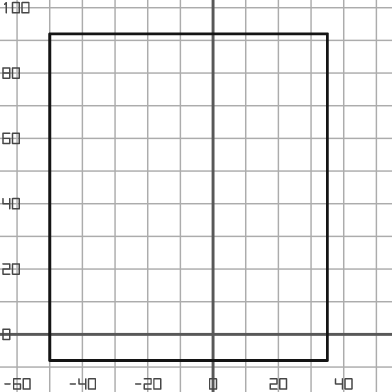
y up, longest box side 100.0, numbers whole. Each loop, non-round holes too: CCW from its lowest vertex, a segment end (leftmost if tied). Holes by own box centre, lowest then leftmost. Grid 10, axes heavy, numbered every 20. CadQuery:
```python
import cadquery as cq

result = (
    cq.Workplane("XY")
    .moveTo(-50.0, -8.0)
    .lineTo(35.0, -8.0)
    .lineTo(35.0, 92.0)
    .lineTo(-50.0, 92.0)
    .close()
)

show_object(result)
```